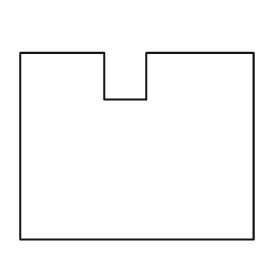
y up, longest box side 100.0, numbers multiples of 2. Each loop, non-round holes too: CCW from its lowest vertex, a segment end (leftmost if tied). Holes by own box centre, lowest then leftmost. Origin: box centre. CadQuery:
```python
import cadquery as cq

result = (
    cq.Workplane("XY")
    .moveTo(-50.0, -40.0)
    .lineTo(50.0, -40.0)
    .lineTo(50.0, 40.0)
    .lineTo(4.0, 40.0)
    .lineTo(4.0, 20.0)
    .lineTo(-14.0, 20.0)
    .lineTo(-14.0, 40.0)
    .lineTo(-50.0, 40.0)
    .close()
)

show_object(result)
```